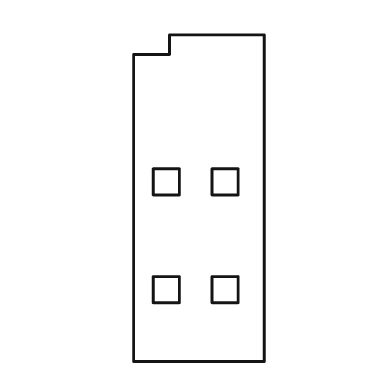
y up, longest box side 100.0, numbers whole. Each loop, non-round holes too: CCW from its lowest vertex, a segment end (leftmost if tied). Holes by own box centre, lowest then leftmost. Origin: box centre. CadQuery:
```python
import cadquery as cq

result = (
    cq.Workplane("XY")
    .moveTo(-20.0, -50.0)
    .lineTo(20.0, -50.0)
    .lineTo(20.0, 50.0)
    .lineTo(-9.0, 50.0)
    .lineTo(-9.0, 44.0)
    .lineTo(-20.0, 44.0)
    .close()
    .moveTo(-14.0, -32.0)
    .lineTo(-6.0, -32.0)
    .lineTo(-6.0, -24.0)
    .lineTo(-14.0, -24.0)
    .close()
    .moveTo(4.0, -32.0)
    .lineTo(12.0, -32.0)
    .lineTo(12.0, -24.0)
    .lineTo(4.0, -24.0)
    .close()
    .moveTo(-14.0, 1.0)
    .lineTo(-6.0, 1.0)
    .lineTo(-6.0, 9.0)
    .lineTo(-14.0, 9.0)
    .close()
    .moveTo(4.0, 1.0)
    .lineTo(12.0, 1.0)
    .lineTo(12.0, 9.0)
    .lineTo(4.0, 9.0)
    .close()
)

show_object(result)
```